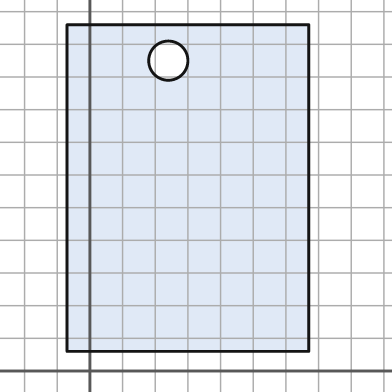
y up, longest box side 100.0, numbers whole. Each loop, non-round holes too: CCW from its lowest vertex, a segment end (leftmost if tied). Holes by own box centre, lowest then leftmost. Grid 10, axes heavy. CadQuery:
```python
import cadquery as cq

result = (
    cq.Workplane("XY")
    .moveTo(-7.0, 6.0)
    .lineTo(67.0, 6.0)
    .lineTo(67.0, 106.0)
    .lineTo(-7.0, 106.0)
    .close()
    .moveTo(24.0, 95.0)
    .circle(6.0)
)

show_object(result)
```